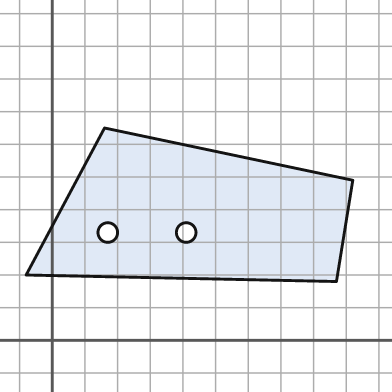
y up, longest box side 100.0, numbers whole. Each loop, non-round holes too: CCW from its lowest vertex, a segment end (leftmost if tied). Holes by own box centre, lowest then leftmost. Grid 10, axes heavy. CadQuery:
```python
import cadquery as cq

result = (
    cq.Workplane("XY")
    .moveTo(87.0, 18.0)
    .lineTo(92.0, 49.0)
    .lineTo(16.0, 65.0)
    .lineTo(-8.0, 20.0)
    .close()
    .moveTo(17.0, 33.0)
    .circle(3.0)
    .moveTo(41.0, 33.0)
    .circle(3.0)
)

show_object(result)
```